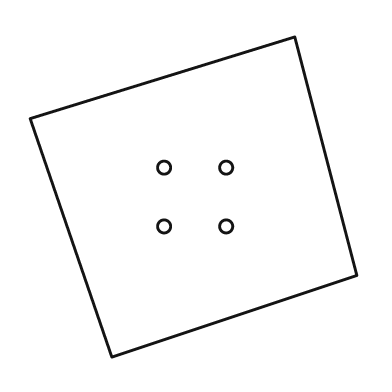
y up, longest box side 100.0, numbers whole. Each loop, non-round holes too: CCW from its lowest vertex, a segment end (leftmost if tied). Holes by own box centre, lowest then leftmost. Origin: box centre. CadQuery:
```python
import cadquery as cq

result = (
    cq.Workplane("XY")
    .moveTo(-25.0, -49.0)
    .lineTo(50.0, -24.0)
    .lineTo(31.0, 49.0)
    .lineTo(-50.0, 24.0)
    .close()
    .moveTo(-9.0, -9.0)
    .circle(2.0)
    .moveTo(10.0, -9.0)
    .circle(2.0)
    .moveTo(-9.0, 9.0)
    .circle(2.0)
    .moveTo(10.0, 9.0)
    .circle(2.0)
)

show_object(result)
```